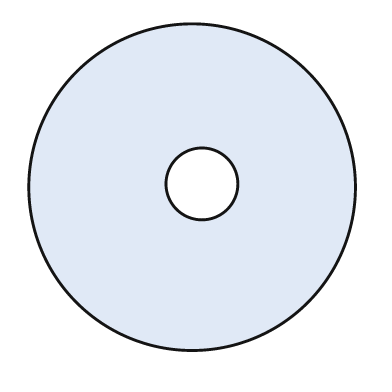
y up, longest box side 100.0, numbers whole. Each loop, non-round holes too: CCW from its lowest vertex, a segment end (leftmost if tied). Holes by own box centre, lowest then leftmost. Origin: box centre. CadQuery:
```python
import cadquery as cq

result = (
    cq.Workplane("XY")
    .moveTo(0.0, 0.0)
    .circle(50.0)
    .moveTo(3.0, 1.0)
    .circle(11.0)
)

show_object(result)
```